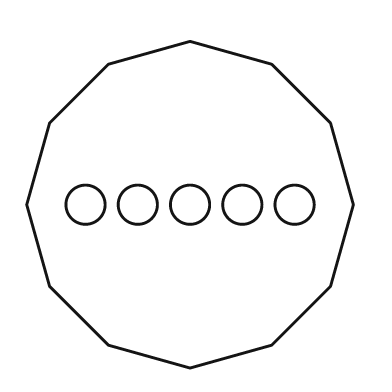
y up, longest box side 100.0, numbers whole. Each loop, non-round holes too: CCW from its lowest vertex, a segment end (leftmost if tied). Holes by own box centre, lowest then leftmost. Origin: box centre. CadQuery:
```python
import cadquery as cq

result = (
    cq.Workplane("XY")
    .moveTo(0.0, -50.0)
    .lineTo(25.0, -43.0)
    .lineTo(43.0, -25.0)
    .lineTo(50.0, 0.0)
    .lineTo(43.0, 25.0)
    .lineTo(25.0, 43.0)
    .lineTo(0.0, 50.0)
    .lineTo(-25.0, 43.0)
    .lineTo(-43.0, 25.0)
    .lineTo(-50.0, 0.0)
    .lineTo(-43.0, -25.0)
    .lineTo(-25.0, -43.0)
    .close()
    .moveTo(-32.0, 0.0)
    .circle(6.0)
    .moveTo(-16.0, 0.0)
    .circle(6.0)
    .moveTo(0.0, 0.0)
    .circle(6.0)
    .moveTo(16.0, 0.0)
    .circle(6.0)
    .moveTo(32.0, 0.0)
    .circle(6.0)
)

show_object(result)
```